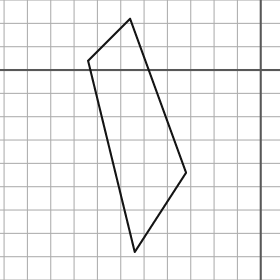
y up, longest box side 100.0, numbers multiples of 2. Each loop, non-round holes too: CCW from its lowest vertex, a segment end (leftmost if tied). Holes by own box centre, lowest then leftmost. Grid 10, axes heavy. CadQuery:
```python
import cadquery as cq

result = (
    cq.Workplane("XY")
    .moveTo(-54.0, -78.0)
    .lineTo(-32.0, -44.0)
    .lineTo(-56.0, 22.0)
    .lineTo(-74.0, 4.0)
    .close()
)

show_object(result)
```